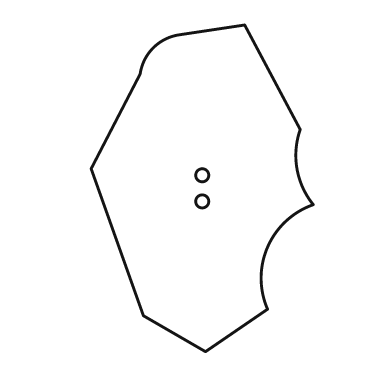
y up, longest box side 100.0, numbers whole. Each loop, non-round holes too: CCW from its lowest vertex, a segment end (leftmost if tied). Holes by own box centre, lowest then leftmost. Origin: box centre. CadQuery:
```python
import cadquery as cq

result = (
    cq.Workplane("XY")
    .moveTo(1.0, -50.0)
    .lineTo(20.0, -37.0)
    .threePointArc((20.0, -18.0), (34.0, -5.0))
    .threePointArc((29.0, 6.0), (30.0, 18.0))
    .lineTo(13.0, 50.0)
    .lineTo(-7.0, 47.0)
    .threePointArc((-15.0, 43.0), (-19.0, 35.0))
    .lineTo(-34.0, 6.0)
    .lineTo(-18.0, -39.0)
    .close()
    .moveTo(0.0, -4.0)
    .circle(2.0)
    .moveTo(0.0, 4.0)
    .circle(2.0)
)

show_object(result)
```